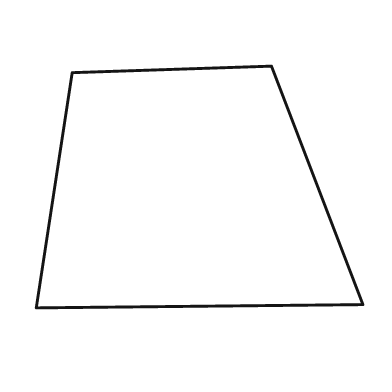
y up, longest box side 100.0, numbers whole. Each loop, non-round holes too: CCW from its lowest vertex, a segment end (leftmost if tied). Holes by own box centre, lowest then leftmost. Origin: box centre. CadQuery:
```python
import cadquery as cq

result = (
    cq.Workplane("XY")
    .moveTo(-50.0, -37.0)
    .lineTo(50.0, -36.0)
    .lineTo(22.0, 37.0)
    .lineTo(-39.0, 35.0)
    .close()
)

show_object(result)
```